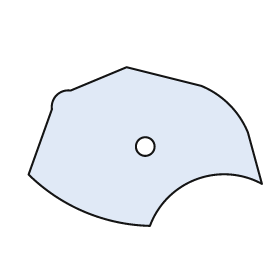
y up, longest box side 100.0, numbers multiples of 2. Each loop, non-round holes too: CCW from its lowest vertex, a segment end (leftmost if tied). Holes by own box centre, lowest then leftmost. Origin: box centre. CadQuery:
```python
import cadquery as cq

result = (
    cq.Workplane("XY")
    .moveTo(2.0, -34.0)
    .threePointArc((22.0, -14.0), (50.0, -16.0))
    .lineTo(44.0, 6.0)
    .threePointArc((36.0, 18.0), (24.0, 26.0))
    .lineTo(-8.0, 34.0)
    .lineTo(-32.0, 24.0)
    .threePointArc((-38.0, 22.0), (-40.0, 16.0))
    .lineTo(-50.0, -12.0)
    .threePointArc((-26.0, -28.0), (2.0, -34.0))
    .close()
    .moveTo(0.0, 0.0)
    .circle(4.0)
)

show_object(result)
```